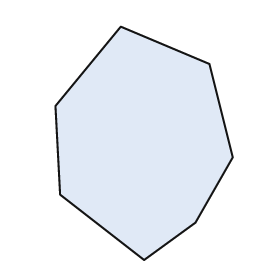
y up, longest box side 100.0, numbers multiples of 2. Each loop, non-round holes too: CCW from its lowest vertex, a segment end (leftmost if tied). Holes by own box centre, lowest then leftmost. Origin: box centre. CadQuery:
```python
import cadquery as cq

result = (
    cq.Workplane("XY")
    .moveTo(0.0, -50.0)
    .lineTo(22.0, -34.0)
    .lineTo(38.0, -6.0)
    .lineTo(28.0, 34.0)
    .lineTo(-10.0, 50.0)
    .lineTo(-38.0, 16.0)
    .lineTo(-36.0, -22.0)
    .close()
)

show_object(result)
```